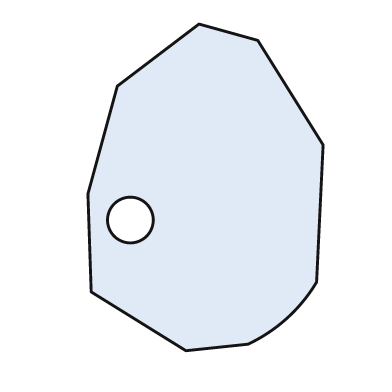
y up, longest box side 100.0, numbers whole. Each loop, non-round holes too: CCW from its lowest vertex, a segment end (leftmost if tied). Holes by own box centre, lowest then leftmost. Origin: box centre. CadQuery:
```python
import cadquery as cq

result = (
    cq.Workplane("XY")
    .moveTo(-6.0, -50.0)
    .lineTo(13.0, -48.0)
    .threePointArc((25.0, -40.0), (34.0, -29.0))
    .lineTo(36.0, 13.0)
    .lineTo(16.0, 45.0)
    .lineTo(-2.0, 50.0)
    .lineTo(-27.0, 31.0)
    .lineTo(-36.0, -2.0)
    .lineTo(-35.0, -32.0)
    .close()
    .moveTo(-23.0, -10.0)
    .circle(7.0)
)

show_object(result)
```